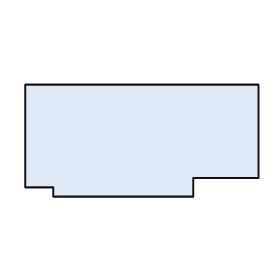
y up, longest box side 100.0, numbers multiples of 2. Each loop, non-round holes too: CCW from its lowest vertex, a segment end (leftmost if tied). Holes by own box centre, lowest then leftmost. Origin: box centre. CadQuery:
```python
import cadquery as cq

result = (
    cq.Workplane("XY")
    .moveTo(-38.0, -24.0)
    .lineTo(22.0, -24.0)
    .lineTo(22.0, -16.0)
    .lineTo(50.0, -16.0)
    .lineTo(50.0, 24.0)
    .lineTo(-50.0, 24.0)
    .lineTo(-50.0, -20.0)
    .lineTo(-38.0, -20.0)
    .close()
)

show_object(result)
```